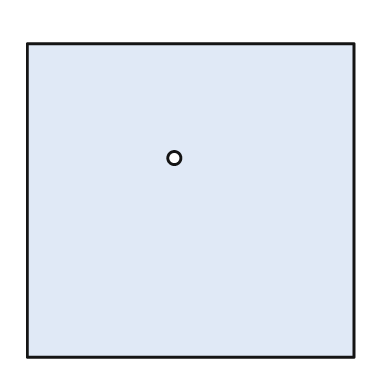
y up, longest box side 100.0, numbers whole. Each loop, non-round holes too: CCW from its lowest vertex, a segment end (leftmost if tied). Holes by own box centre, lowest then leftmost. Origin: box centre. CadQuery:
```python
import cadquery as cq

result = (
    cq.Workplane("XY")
    .moveTo(-50.0, -48.0)
    .lineTo(50.0, -48.0)
    .lineTo(50.0, 48.0)
    .lineTo(-50.0, 48.0)
    .close()
    .moveTo(-5.0, 13.0)
    .circle(2.0)
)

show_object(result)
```